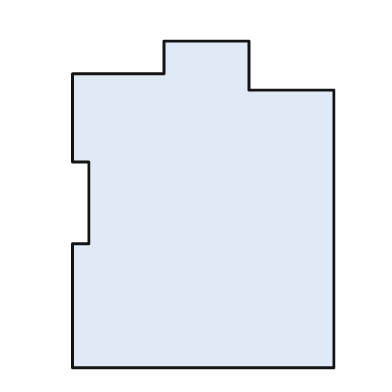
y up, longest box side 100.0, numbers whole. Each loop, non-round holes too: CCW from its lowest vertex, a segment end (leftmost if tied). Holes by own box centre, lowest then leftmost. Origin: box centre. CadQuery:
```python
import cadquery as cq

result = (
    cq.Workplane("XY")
    .moveTo(-40.0, -50.0)
    .lineTo(40.0, -50.0)
    .lineTo(40.0, 35.0)
    .lineTo(14.0, 35.0)
    .lineTo(14.0, 50.0)
    .lineTo(-12.0, 50.0)
    .lineTo(-12.0, 40.0)
    .lineTo(-40.0, 40.0)
    .lineTo(-40.0, 13.0)
    .lineTo(-35.0, 13.0)
    .lineTo(-35.0, -12.0)
    .lineTo(-40.0, -12.0)
    .close()
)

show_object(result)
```